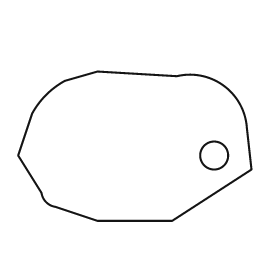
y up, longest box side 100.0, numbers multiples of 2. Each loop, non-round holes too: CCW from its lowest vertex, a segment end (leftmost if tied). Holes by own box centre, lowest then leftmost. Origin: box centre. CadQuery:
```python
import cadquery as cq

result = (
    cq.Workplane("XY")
    .moveTo(-16.0, -32.0)
    .lineTo(16.0, -32.0)
    .lineTo(50.0, -10.0)
    .lineTo(48.0, 8.0)
    .threePointArc((38.0, 26.0), (18.0, 30.0))
    .lineTo(-16.0, 32.0)
    .lineTo(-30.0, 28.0)
    .threePointArc((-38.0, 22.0), (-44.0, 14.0))
    .lineTo(-50.0, -4.0)
    .lineTo(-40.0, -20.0)
    .threePointArc((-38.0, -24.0), (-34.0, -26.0))
    .close()
    .moveTo(34.0, -4.0)
    .circle(6.0)
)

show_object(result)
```